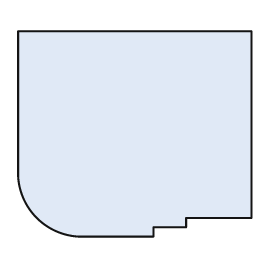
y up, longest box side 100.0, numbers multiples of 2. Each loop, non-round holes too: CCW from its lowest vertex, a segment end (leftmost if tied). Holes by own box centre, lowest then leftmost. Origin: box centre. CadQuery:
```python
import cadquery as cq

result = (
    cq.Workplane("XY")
    .moveTo(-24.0, -44.0)
    .lineTo(8.0, -44.0)
    .lineTo(8.0, -40.0)
    .lineTo(22.0, -40.0)
    .lineTo(22.0, -36.0)
    .lineTo(50.0, -36.0)
    .lineTo(50.0, 44.0)
    .lineTo(-50.0, 44.0)
    .lineTo(-50.0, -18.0)
    .threePointArc((-42.0, -36.0), (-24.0, -44.0))
    .close()
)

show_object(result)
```